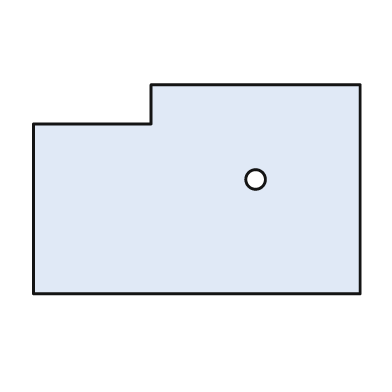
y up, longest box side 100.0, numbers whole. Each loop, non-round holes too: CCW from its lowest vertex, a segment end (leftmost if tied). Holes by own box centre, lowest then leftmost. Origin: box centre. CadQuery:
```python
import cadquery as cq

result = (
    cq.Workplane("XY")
    .moveTo(-50.0, -32.0)
    .lineTo(50.0, -32.0)
    .lineTo(50.0, 32.0)
    .lineTo(-14.0, 32.0)
    .lineTo(-14.0, 20.0)
    .lineTo(-50.0, 20.0)
    .close()
    .moveTo(18.0, 3.0)
    .circle(3.0)
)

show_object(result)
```